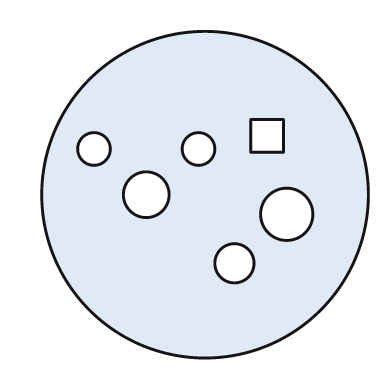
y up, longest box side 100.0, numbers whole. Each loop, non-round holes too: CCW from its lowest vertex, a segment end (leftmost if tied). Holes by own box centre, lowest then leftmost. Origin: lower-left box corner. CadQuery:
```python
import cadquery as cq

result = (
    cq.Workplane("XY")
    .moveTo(50.0, 50.0)
    .circle(50.0)
    .moveTo(59.0, 29.0)
    .circle(6.0)
    .moveTo(75.0, 44.0)
    .circle(8.0)
    .moveTo(32.0, 50.0)
    .circle(7.0)
    .moveTo(16.0, 64.0)
    .circle(5.0)
    .moveTo(48.0, 64.0)
    .circle(5.0)
    .moveTo(64.0, 63.0)
    .lineTo(74.0, 63.0)
    .lineTo(74.0, 73.0)
    .lineTo(64.0, 73.0)
    .close()
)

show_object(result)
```